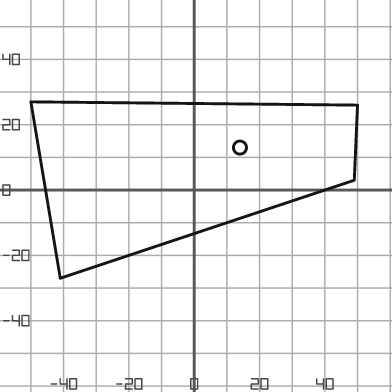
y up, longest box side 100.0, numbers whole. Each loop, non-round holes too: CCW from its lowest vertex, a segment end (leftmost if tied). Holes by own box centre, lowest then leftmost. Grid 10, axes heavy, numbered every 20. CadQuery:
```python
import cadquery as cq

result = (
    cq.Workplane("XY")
    .moveTo(-41.0, -27.0)
    .lineTo(49.0, 3.0)
    .lineTo(50.0, 26.0)
    .lineTo(-50.0, 27.0)
    .close()
    .moveTo(14.0, 13.0)
    .circle(2.0)
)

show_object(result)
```